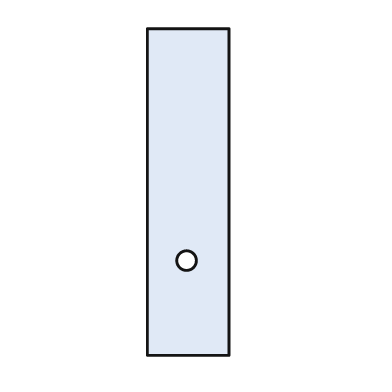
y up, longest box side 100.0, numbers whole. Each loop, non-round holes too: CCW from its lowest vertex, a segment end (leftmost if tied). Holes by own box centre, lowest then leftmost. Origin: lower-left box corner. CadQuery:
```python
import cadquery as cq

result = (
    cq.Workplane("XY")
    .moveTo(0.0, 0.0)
    .lineTo(25.0, 0.0)
    .lineTo(25.0, 100.0)
    .lineTo(0.0, 100.0)
    .close()
    .moveTo(12.0, 29.0)
    .circle(3.0)
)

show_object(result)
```